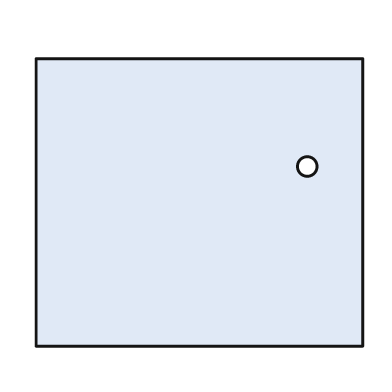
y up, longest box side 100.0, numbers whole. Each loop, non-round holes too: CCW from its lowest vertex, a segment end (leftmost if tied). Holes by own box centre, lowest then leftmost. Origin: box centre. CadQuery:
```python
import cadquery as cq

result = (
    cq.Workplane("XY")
    .moveTo(-50.0, -44.0)
    .lineTo(50.0, -44.0)
    .lineTo(50.0, 44.0)
    .lineTo(-50.0, 44.0)
    .close()
    .moveTo(33.0, 11.0)
    .circle(3.0)
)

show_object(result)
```